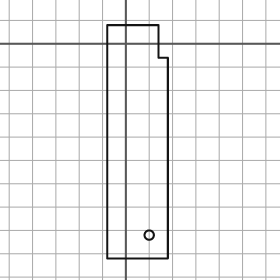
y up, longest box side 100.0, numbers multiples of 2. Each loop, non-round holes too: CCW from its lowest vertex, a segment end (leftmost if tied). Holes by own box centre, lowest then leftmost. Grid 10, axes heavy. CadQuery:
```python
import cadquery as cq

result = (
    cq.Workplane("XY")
    .moveTo(-8.0, -92.0)
    .lineTo(18.0, -92.0)
    .lineTo(18.0, -6.0)
    .lineTo(14.0, -6.0)
    .lineTo(14.0, 8.0)
    .lineTo(-8.0, 8.0)
    .close()
    .moveTo(10.0, -82.0)
    .circle(2.0)
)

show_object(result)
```